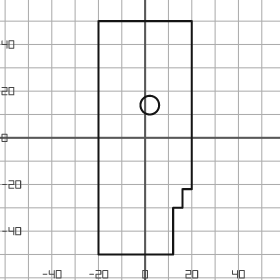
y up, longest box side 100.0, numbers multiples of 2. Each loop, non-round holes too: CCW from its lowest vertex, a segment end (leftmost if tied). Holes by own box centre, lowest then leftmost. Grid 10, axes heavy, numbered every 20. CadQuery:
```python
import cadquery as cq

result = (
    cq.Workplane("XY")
    .moveTo(-20.0, -50.0)
    .lineTo(12.0, -50.0)
    .lineTo(12.0, -30.0)
    .lineTo(16.0, -30.0)
    .lineTo(16.0, -22.0)
    .lineTo(20.0, -22.0)
    .lineTo(20.0, 50.0)
    .lineTo(-20.0, 50.0)
    .close()
    .moveTo(2.0, 14.0)
    .circle(4.0)
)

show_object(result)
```